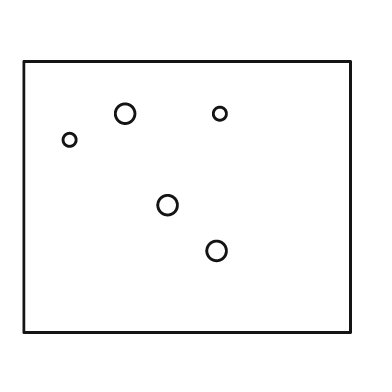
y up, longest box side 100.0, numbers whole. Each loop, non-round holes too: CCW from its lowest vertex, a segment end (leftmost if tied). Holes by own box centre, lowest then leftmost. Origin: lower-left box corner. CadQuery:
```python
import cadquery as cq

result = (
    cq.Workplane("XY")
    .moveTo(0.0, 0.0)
    .lineTo(100.0, 0.0)
    .lineTo(100.0, 83.0)
    .lineTo(0.0, 83.0)
    .close()
    .moveTo(59.0, 25.0)
    .circle(3.0)
    .moveTo(44.0, 39.0)
    .circle(3.0)
    .moveTo(14.0, 59.0)
    .circle(2.0)
    .moveTo(31.0, 67.0)
    .circle(3.0)
    .moveTo(60.0, 67.0)
    .circle(2.0)
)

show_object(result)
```